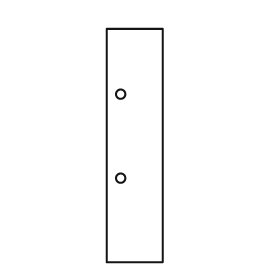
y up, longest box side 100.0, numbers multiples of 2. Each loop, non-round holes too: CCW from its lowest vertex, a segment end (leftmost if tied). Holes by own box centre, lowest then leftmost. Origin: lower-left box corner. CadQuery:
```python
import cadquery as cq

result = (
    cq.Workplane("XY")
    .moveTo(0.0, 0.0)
    .lineTo(24.0, 0.0)
    .lineTo(24.0, 100.0)
    .lineTo(0.0, 100.0)
    .close()
    .moveTo(6.0, 36.0)
    .circle(2.0)
    .moveTo(6.0, 72.0)
    .circle(2.0)
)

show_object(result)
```